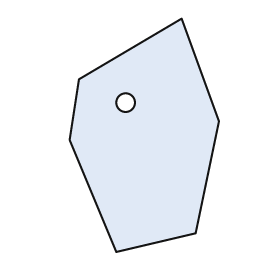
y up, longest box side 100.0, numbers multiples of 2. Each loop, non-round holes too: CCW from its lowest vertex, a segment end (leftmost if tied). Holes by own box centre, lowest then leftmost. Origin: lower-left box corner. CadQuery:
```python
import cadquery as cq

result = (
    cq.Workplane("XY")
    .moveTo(20.0, 0.0)
    .lineTo(54.0, 8.0)
    .lineTo(64.0, 56.0)
    .lineTo(48.0, 100.0)
    .lineTo(4.0, 74.0)
    .lineTo(0.0, 48.0)
    .close()
    .moveTo(24.0, 64.0)
    .circle(4.0)
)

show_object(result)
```